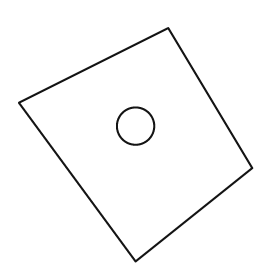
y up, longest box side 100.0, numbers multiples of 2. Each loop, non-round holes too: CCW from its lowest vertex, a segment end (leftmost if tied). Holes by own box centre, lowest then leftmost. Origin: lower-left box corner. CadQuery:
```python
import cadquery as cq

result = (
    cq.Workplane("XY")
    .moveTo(50.0, 0.0)
    .lineTo(100.0, 40.0)
    .lineTo(64.0, 100.0)
    .lineTo(0.0, 68.0)
    .close()
    .moveTo(50.0, 58.0)
    .circle(8.0)
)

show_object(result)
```